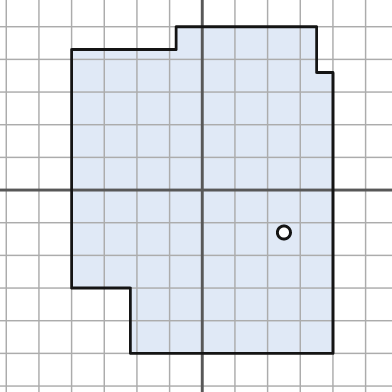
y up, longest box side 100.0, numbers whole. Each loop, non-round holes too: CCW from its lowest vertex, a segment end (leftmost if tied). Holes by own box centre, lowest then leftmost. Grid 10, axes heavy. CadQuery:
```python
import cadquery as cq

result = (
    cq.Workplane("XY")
    .moveTo(-22.0, -50.0)
    .lineTo(40.0, -50.0)
    .lineTo(40.0, 36.0)
    .lineTo(35.0, 36.0)
    .lineTo(35.0, 50.0)
    .lineTo(-8.0, 50.0)
    .lineTo(-8.0, 43.0)
    .lineTo(-40.0, 43.0)
    .lineTo(-40.0, -30.0)
    .lineTo(-22.0, -30.0)
    .close()
    .moveTo(25.0, -13.0)
    .circle(2.0)
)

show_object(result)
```